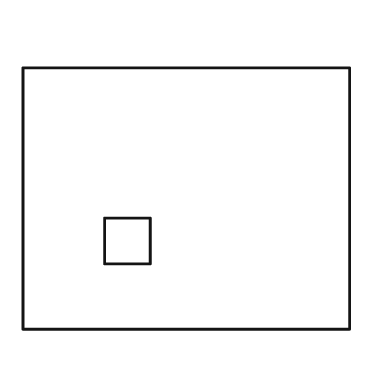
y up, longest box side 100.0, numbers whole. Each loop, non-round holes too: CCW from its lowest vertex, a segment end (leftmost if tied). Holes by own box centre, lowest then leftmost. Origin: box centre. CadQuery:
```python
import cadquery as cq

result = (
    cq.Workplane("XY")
    .moveTo(-50.0, -40.0)
    .lineTo(50.0, -40.0)
    .lineTo(50.0, 40.0)
    .lineTo(-50.0, 40.0)
    .close()
    .moveTo(-25.0, -20.0)
    .lineTo(-11.0, -20.0)
    .lineTo(-11.0, -6.0)
    .lineTo(-25.0, -6.0)
    .close()
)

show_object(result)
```